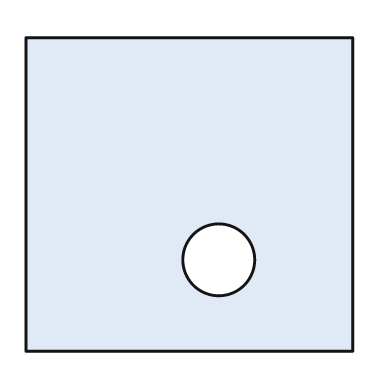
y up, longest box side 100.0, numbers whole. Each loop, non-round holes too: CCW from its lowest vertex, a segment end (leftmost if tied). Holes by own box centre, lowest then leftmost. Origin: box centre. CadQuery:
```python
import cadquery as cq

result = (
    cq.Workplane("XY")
    .moveTo(-50.0, -48.0)
    .lineTo(50.0, -48.0)
    .lineTo(50.0, 48.0)
    .lineTo(-50.0, 48.0)
    .close()
    .moveTo(9.0, -20.0)
    .circle(11.0)
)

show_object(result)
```